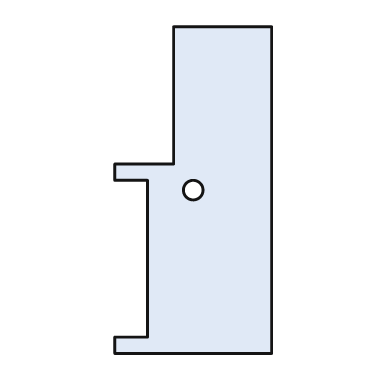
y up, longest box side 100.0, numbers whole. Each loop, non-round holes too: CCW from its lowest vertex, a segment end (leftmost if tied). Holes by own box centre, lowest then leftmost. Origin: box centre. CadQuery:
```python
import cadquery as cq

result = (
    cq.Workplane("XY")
    .moveTo(-24.0, -50.0)
    .lineTo(24.0, -50.0)
    .lineTo(24.0, 50.0)
    .lineTo(-6.0, 50.0)
    .lineTo(-6.0, 8.0)
    .lineTo(-24.0, 8.0)
    .lineTo(-24.0, 3.0)
    .lineTo(-14.0, 3.0)
    .lineTo(-14.0, -45.0)
    .lineTo(-24.0, -45.0)
    .close()
    .moveTo(0.0, 0.0)
    .circle(3.0)
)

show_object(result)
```